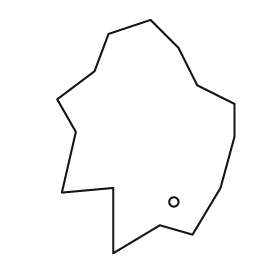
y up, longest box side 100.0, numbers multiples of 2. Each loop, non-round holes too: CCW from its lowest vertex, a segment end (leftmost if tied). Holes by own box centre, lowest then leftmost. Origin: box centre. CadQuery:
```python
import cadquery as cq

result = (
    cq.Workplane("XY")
    .moveTo(-14.0, -50.0)
    .lineTo(6.0, -38.0)
    .lineTo(20.0, -42.0)
    .lineTo(32.0, -22.0)
    .lineTo(38.0, 0.0)
    .lineTo(38.0, 14.0)
    .lineTo(22.0, 22.0)
    .lineTo(14.0, 38.0)
    .lineTo(2.0, 50.0)
    .lineTo(-16.0, 44.0)
    .lineTo(-22.0, 28.0)
    .lineTo(-38.0, 16.0)
    .lineTo(-30.0, 2.0)
    .lineTo(-36.0, -24.0)
    .lineTo(-14.0, -22.0)
    .close()
    .moveTo(12.0, -28.0)
    .circle(2.0)
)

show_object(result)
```